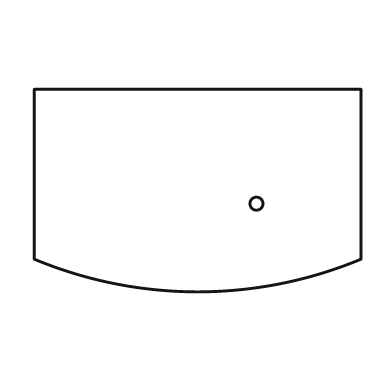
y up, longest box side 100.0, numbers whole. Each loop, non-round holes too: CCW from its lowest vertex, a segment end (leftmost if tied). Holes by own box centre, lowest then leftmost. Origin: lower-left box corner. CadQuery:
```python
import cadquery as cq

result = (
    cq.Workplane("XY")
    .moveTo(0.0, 10.0)
    .threePointArc((50.0, 0.0), (100.0, 10.0))
    .lineTo(100.0, 62.0)
    .lineTo(0.0, 62.0)
    .close()
    .moveTo(68.0, 27.0)
    .circle(2.0)
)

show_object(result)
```